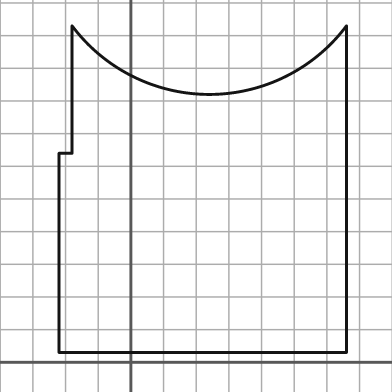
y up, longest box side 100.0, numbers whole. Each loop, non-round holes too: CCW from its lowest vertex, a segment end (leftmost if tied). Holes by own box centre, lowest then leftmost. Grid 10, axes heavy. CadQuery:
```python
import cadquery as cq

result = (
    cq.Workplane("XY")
    .moveTo(-22.0, 3.0)
    .lineTo(66.0, 3.0)
    .lineTo(66.0, 103.0)
    .threePointArc((24.0, 82.0), (-18.0, 103.0))
    .lineTo(-18.0, 64.0)
    .lineTo(-22.0, 64.0)
    .close()
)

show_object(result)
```